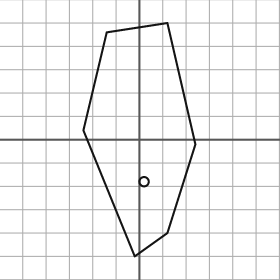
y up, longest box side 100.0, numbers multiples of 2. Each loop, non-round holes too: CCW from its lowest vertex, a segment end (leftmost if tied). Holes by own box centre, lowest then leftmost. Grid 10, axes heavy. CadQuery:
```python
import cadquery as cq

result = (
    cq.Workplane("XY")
    .moveTo(-2.0, -50.0)
    .lineTo(12.0, -40.0)
    .lineTo(24.0, -2.0)
    .lineTo(12.0, 50.0)
    .lineTo(-14.0, 46.0)
    .lineTo(-24.0, 4.0)
    .close()
    .moveTo(2.0, -18.0)
    .circle(2.0)
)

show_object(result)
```